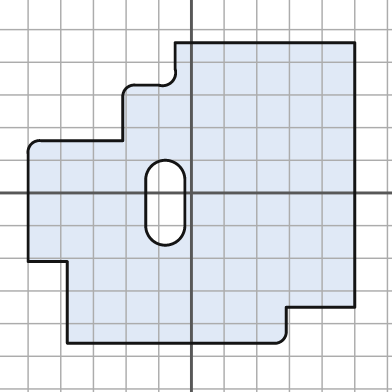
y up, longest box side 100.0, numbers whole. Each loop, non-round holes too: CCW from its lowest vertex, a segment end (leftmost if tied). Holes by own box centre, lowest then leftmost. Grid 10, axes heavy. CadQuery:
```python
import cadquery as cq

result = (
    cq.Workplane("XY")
    .moveTo(-38.0, -46.0)
    .lineTo(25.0, -46.0)
    .threePointArc((28.0, -45.0), (29.0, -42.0))
    .lineTo(29.0, -35.0)
    .lineTo(50.0, -35.0)
    .lineTo(50.0, 46.0)
    .lineTo(-5.0, 46.0)
    .lineTo(-5.0, 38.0)
    .threePointArc((-6.0, 34.0), (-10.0, 33.0))
    .lineTo(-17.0, 33.0)
    .threePointArc((-20.0, 32.0), (-21.0, 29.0))
    .lineTo(-21.0, 16.0)
    .lineTo(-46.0, 16.0)
    .threePointArc((-49.0, 15.0), (-50.0, 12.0))
    .lineTo(-50.0, -21.0)
    .lineTo(-38.0, -21.0)
    .close()
    .moveTo(-14.0, -10.0)
    .threePointArc((-8.0, -16.0), (-2.0, -10.0))
    .lineTo(-2.0, 4.0)
    .threePointArc((-8.0, 10.0), (-14.0, 4.0))
    .close()
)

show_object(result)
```